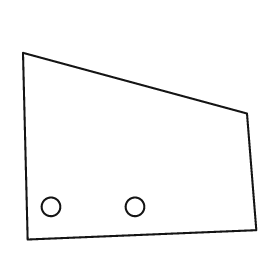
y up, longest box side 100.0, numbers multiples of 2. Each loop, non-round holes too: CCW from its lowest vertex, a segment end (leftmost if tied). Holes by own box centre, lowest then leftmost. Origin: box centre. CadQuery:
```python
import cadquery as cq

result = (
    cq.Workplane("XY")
    .moveTo(-48.0, -40.0)
    .lineTo(50.0, -36.0)
    .lineTo(46.0, 14.0)
    .lineTo(-50.0, 40.0)
    .close()
    .moveTo(-38.0, -26.0)
    .circle(4.0)
    .moveTo(-2.0, -26.0)
    .circle(4.0)
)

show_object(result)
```